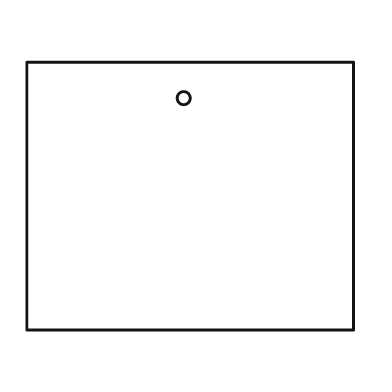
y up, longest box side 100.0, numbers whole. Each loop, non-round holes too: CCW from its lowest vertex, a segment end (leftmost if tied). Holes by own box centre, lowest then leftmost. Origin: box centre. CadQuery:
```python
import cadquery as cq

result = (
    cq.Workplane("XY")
    .moveTo(-50.0, -41.0)
    .lineTo(50.0, -41.0)
    .lineTo(50.0, 41.0)
    .lineTo(-50.0, 41.0)
    .close()
    .moveTo(-2.0, 30.0)
    .circle(2.0)
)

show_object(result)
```